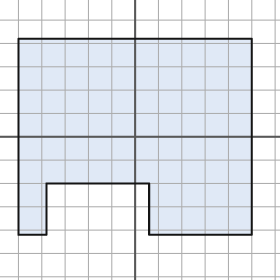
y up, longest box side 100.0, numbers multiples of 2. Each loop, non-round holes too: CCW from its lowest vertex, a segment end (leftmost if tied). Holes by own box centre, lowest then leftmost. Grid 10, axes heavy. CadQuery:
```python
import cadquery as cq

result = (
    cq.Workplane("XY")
    .moveTo(-50.0, -42.0)
    .lineTo(-38.0, -42.0)
    .lineTo(-38.0, -20.0)
    .lineTo(6.0, -20.0)
    .lineTo(6.0, -42.0)
    .lineTo(50.0, -42.0)
    .lineTo(50.0, 42.0)
    .lineTo(-50.0, 42.0)
    .close()
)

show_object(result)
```